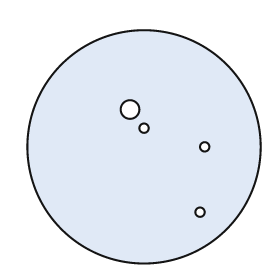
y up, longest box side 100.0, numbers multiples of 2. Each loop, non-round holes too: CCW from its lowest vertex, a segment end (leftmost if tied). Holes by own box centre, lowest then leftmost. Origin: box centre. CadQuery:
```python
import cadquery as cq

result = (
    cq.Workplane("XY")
    .moveTo(0.0, 0.0)
    .circle(50.0)
    .moveTo(24.0, -28.0)
    .circle(2.0)
    .moveTo(26.0, 0.0)
    .circle(2.0)
    .moveTo(0.0, 8.0)
    .circle(2.0)
    .moveTo(-6.0, 16.0)
    .circle(4.0)
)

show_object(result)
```